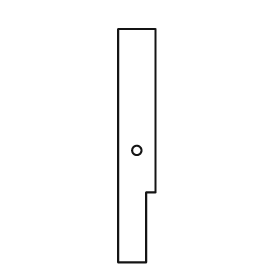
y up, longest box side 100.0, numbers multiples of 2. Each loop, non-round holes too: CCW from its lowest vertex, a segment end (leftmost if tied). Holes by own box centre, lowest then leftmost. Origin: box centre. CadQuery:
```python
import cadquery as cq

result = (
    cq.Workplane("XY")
    .moveTo(-8.0, -50.0)
    .lineTo(4.0, -50.0)
    .lineTo(4.0, -20.0)
    .lineTo(8.0, -20.0)
    .lineTo(8.0, 50.0)
    .lineTo(-8.0, 50.0)
    .close()
    .moveTo(0.0, -2.0)
    .circle(2.0)
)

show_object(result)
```